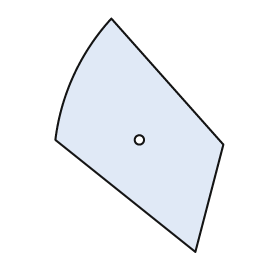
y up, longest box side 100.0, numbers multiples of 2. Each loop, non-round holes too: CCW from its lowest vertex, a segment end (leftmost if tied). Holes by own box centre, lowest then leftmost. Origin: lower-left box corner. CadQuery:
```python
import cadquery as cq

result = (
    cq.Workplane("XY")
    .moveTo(60.0, 0.0)
    .lineTo(72.0, 46.0)
    .lineTo(24.0, 100.0)
    .threePointArc((8.0, 76.0), (0.0, 48.0))
    .close()
    .moveTo(36.0, 48.0)
    .circle(2.0)
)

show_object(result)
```